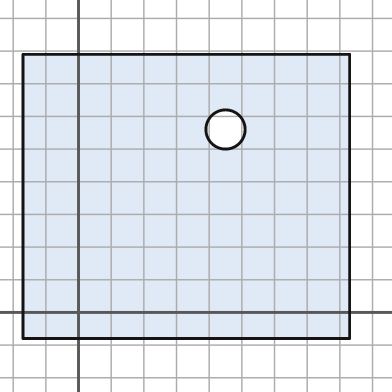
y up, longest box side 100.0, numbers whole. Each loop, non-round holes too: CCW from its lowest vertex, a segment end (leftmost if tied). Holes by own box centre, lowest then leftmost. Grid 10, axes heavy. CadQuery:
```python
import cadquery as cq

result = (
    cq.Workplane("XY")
    .moveTo(-17.0, -8.0)
    .lineTo(83.0, -8.0)
    .lineTo(83.0, 79.0)
    .lineTo(-17.0, 79.0)
    .close()
    .moveTo(45.0, 56.0)
    .circle(6.0)
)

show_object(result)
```